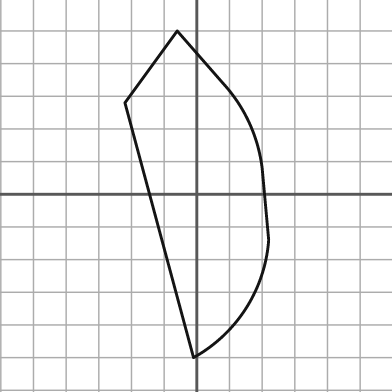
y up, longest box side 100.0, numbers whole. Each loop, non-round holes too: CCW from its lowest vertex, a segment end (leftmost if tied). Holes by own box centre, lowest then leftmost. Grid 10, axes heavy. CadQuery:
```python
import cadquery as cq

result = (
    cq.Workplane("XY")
    .moveTo(-1.0, -50.0)
    .threePointArc((15.0, -35.0), (22.0, -14.0))
    .lineTo(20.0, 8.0)
    .threePointArc((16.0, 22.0), (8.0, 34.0))
    .lineTo(-6.0, 50.0)
    .lineTo(-22.0, 28.0)
    .close()
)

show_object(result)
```